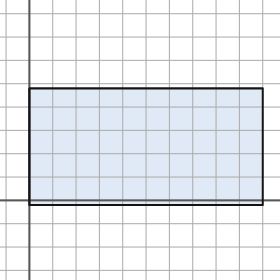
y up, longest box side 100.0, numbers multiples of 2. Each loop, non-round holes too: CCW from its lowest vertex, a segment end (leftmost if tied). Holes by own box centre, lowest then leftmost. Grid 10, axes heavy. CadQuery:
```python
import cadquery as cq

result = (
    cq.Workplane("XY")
    .moveTo(0.0, -2.0)
    .lineTo(100.0, -2.0)
    .lineTo(100.0, 48.0)
    .lineTo(0.0, 48.0)
    .close()
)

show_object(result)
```